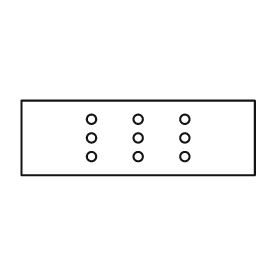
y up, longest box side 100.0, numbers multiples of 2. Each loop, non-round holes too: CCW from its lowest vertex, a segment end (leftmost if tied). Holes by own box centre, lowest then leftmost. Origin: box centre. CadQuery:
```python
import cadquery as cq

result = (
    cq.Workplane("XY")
    .moveTo(-50.0, -16.0)
    .lineTo(50.0, -16.0)
    .lineTo(50.0, 16.0)
    .lineTo(-50.0, 16.0)
    .close()
    .moveTo(-20.0, -8.0)
    .circle(2.0)
    .moveTo(0.0, -8.0)
    .circle(2.0)
    .moveTo(20.0, -8.0)
    .circle(2.0)
    .moveTo(-20.0, 0.0)
    .circle(2.0)
    .moveTo(0.0, 0.0)
    .circle(2.0)
    .moveTo(20.0, 0.0)
    .circle(2.0)
    .moveTo(-20.0, 8.0)
    .circle(2.0)
    .moveTo(0.0, 8.0)
    .circle(2.0)
    .moveTo(20.0, 8.0)
    .circle(2.0)
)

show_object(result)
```